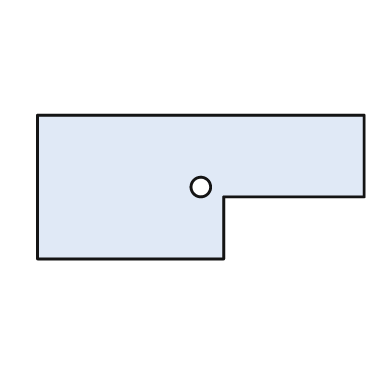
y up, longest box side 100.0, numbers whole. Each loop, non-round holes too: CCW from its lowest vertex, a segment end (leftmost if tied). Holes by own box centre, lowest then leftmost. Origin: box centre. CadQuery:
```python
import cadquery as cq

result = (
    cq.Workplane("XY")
    .moveTo(-50.0, -22.0)
    .lineTo(7.0, -22.0)
    .lineTo(7.0, -3.0)
    .lineTo(50.0, -3.0)
    .lineTo(50.0, 22.0)
    .lineTo(-50.0, 22.0)
    .close()
    .moveTo(0.0, 0.0)
    .circle(3.0)
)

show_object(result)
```